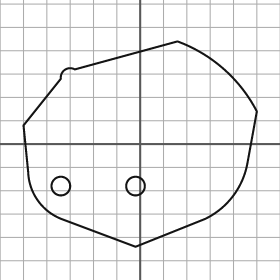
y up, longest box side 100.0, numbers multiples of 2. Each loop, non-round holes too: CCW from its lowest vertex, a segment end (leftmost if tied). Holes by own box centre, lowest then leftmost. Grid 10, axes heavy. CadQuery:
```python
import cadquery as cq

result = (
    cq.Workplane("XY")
    .moveTo(-2.0, -44.0)
    .lineTo(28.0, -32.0)
    .threePointArc((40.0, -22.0), (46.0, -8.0))
    .lineTo(50.0, 14.0)
    .threePointArc((36.0, 32.0), (16.0, 44.0))
    .lineTo(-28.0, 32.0)
    .threePointArc((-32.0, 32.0), (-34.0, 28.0))
    .lineTo(-50.0, 8.0)
    .lineTo(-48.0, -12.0)
    .threePointArc((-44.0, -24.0), (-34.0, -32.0))
    .close()
    .moveTo(-34.0, -18.0)
    .circle(4.0)
    .moveTo(-2.0, -18.0)
    .circle(4.0)
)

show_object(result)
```